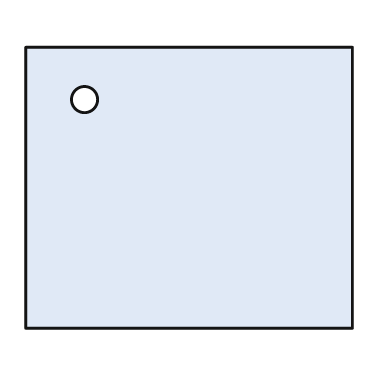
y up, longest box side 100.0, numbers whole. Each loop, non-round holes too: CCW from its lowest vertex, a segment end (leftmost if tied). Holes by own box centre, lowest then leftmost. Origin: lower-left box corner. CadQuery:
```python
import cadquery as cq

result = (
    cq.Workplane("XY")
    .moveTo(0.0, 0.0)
    .lineTo(100.0, 0.0)
    .lineTo(100.0, 86.0)
    .lineTo(0.0, 86.0)
    .close()
    .moveTo(18.0, 70.0)
    .circle(4.0)
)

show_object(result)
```